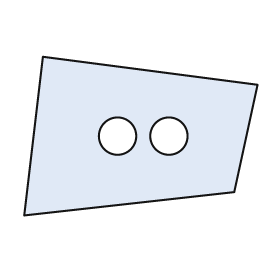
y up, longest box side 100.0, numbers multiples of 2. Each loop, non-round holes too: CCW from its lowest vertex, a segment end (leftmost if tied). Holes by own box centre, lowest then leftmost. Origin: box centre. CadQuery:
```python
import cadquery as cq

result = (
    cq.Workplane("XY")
    .moveTo(-50.0, -34.0)
    .lineTo(40.0, -24.0)
    .lineTo(50.0, 22.0)
    .lineTo(-42.0, 34.0)
    .close()
    .moveTo(-10.0, 0.0)
    .circle(8.0)
    .moveTo(12.0, 0.0)
    .circle(8.0)
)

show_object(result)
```